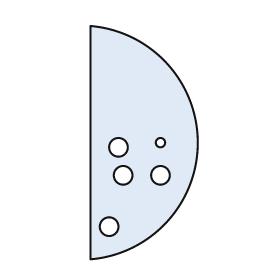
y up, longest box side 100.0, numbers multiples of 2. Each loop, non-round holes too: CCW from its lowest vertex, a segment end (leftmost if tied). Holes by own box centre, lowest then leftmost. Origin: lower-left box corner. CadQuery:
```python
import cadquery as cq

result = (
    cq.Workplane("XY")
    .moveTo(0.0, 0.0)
    .threePointArc((46.0, 50.0), (0.0, 100.0))
    .close()
    .moveTo(8.0, 14.0)
    .circle(4.0)
    .moveTo(14.0, 36.0)
    .circle(4.0)
    .moveTo(30.0, 36.0)
    .circle(4.0)
    .moveTo(12.0, 48.0)
    .circle(4.0)
    .moveTo(30.0, 50.0)
    .circle(2.0)
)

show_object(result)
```